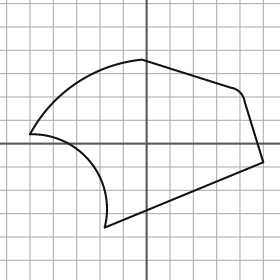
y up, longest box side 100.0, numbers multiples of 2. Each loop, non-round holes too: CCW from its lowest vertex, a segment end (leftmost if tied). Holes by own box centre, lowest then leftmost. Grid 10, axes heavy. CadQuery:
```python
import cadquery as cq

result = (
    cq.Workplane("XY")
    .moveTo(-18.0, -36.0)
    .lineTo(50.0, -8.0)
    .lineTo(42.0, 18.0)
    .threePointArc((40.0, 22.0), (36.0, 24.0))
    .lineTo(-2.0, 36.0)
    .threePointArc((-30.0, 26.0), (-50.0, 4.0))
    .threePointArc((-24.0, -8.0), (-18.0, -36.0))
    .close()
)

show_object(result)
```